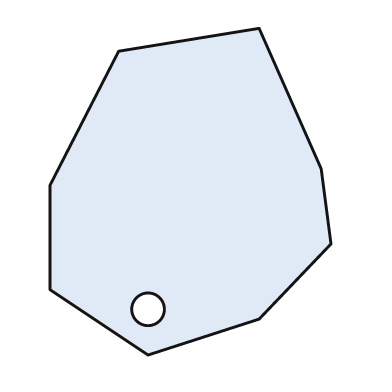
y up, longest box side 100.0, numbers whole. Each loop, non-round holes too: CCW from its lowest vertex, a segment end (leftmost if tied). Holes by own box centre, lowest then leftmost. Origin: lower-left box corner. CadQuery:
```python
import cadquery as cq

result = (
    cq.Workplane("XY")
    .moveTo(30.0, 0.0)
    .lineTo(64.0, 11.0)
    .lineTo(86.0, 34.0)
    .lineTo(83.0, 57.0)
    .lineTo(64.0, 100.0)
    .lineTo(21.0, 93.0)
    .lineTo(0.0, 52.0)
    .lineTo(0.0, 20.0)
    .close()
    .moveTo(30.0, 14.0)
    .circle(5.0)
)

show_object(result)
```